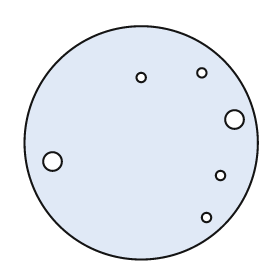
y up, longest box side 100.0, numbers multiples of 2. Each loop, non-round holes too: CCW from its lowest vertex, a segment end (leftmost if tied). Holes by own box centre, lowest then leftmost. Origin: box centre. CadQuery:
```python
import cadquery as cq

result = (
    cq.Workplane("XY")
    .moveTo(0.0, 0.0)
    .circle(50.0)
    .moveTo(28.0, -32.0)
    .circle(2.0)
    .moveTo(34.0, -14.0)
    .circle(2.0)
    .moveTo(-38.0, -8.0)
    .circle(4.0)
    .moveTo(40.0, 10.0)
    .circle(4.0)
    .moveTo(0.0, 28.0)
    .circle(2.0)
    .moveTo(26.0, 30.0)
    .circle(2.0)
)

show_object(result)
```